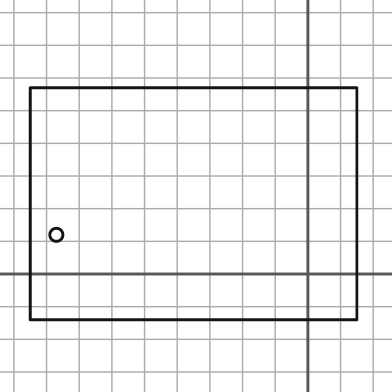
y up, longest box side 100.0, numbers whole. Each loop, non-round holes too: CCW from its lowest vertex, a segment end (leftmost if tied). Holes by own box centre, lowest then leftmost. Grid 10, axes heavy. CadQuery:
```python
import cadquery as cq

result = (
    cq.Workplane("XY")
    .moveTo(-85.0, -14.0)
    .lineTo(15.0, -14.0)
    .lineTo(15.0, 57.0)
    .lineTo(-85.0, 57.0)
    .close()
    .moveTo(-77.0, 12.0)
    .circle(2.0)
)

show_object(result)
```